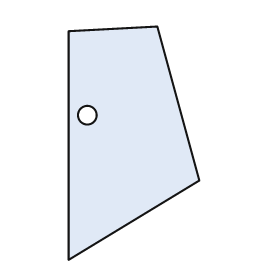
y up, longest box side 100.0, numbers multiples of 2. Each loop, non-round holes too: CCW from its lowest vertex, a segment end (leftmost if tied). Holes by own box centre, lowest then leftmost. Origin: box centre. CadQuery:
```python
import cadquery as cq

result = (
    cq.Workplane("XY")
    .moveTo(-28.0, -50.0)
    .lineTo(28.0, -16.0)
    .lineTo(10.0, 50.0)
    .lineTo(-28.0, 48.0)
    .close()
    .moveTo(-20.0, 12.0)
    .circle(4.0)
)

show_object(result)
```